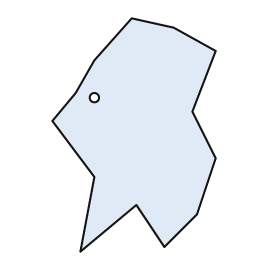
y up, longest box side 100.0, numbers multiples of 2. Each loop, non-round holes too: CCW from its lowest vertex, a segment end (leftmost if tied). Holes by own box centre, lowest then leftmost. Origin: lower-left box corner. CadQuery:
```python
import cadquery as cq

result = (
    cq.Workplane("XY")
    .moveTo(12.0, 0.0)
    .lineTo(36.0, 20.0)
    .lineTo(48.0, 2.0)
    .lineTo(62.0, 16.0)
    .lineTo(70.0, 40.0)
    .lineTo(60.0, 60.0)
    .lineTo(70.0, 86.0)
    .lineTo(52.0, 96.0)
    .lineTo(34.0, 100.0)
    .lineTo(18.0, 82.0)
    .lineTo(10.0, 68.0)
    .lineTo(0.0, 56.0)
    .lineTo(18.0, 32.0)
    .close()
    .moveTo(18.0, 66.0)
    .circle(2.0)
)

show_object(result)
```